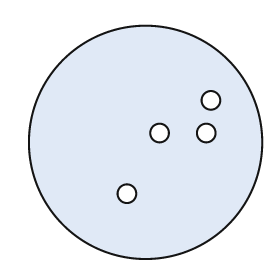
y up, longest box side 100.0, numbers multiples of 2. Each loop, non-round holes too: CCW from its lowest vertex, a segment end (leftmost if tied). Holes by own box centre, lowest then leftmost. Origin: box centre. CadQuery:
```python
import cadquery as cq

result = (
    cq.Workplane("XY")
    .moveTo(0.0, 0.0)
    .circle(50.0)
    .moveTo(-8.0, -22.0)
    .circle(4.0)
    .moveTo(6.0, 4.0)
    .circle(4.0)
    .moveTo(26.0, 4.0)
    .circle(4.0)
    .moveTo(28.0, 18.0)
    .circle(4.0)
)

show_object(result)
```